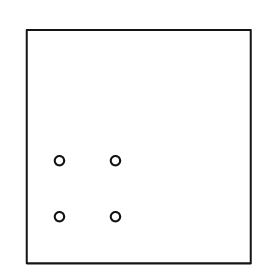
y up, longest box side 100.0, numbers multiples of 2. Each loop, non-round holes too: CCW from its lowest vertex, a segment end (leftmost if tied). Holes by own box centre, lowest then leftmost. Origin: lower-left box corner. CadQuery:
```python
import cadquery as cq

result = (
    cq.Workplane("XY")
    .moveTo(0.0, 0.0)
    .lineTo(96.0, 0.0)
    .lineTo(96.0, 100.0)
    .lineTo(0.0, 100.0)
    .close()
    .moveTo(14.0, 20.0)
    .circle(2.0)
    .moveTo(38.0, 20.0)
    .circle(2.0)
    .moveTo(14.0, 44.0)
    .circle(2.0)
    .moveTo(38.0, 44.0)
    .circle(2.0)
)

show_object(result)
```